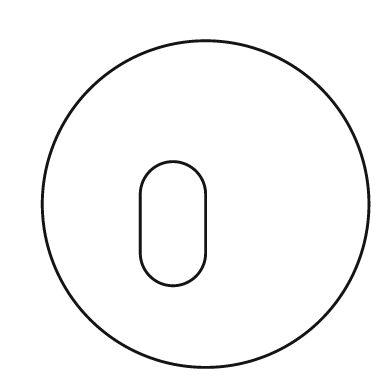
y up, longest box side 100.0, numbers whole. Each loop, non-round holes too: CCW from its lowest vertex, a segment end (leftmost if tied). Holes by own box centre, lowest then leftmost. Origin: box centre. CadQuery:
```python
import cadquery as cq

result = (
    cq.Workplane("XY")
    .moveTo(0.0, 0.0)
    .circle(50.0)
    .moveTo(-20.0, -15.0)
    .threePointArc((-10.0, -25.0), (0.0, -15.0))
    .lineTo(0.0, 3.0)
    .threePointArc((-10.0, 13.0), (-20.0, 3.0))
    .close()
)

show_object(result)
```